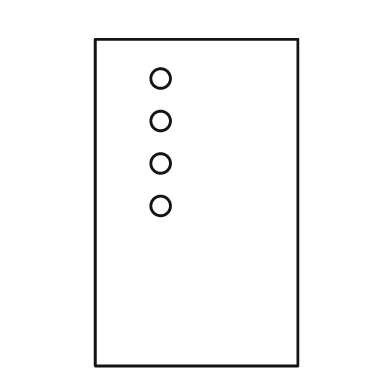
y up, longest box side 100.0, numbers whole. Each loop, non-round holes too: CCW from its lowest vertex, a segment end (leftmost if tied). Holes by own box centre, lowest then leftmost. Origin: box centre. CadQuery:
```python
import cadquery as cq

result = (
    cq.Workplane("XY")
    .moveTo(-31.0, -50.0)
    .lineTo(31.0, -50.0)
    .lineTo(31.0, 50.0)
    .lineTo(-31.0, 50.0)
    .close()
    .moveTo(-11.0, -1.0)
    .circle(3.0)
    .moveTo(-11.0, 12.0)
    .circle(3.0)
    .moveTo(-11.0, 25.0)
    .circle(3.0)
    .moveTo(-11.0, 38.0)
    .circle(3.0)
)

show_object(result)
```